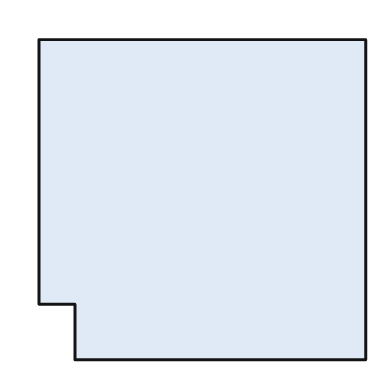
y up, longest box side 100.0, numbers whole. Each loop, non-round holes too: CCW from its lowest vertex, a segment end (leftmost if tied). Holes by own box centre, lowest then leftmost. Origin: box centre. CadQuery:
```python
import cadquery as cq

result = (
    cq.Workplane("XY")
    .moveTo(-39.0, -49.0)
    .lineTo(50.0, -49.0)
    .lineTo(50.0, 49.0)
    .lineTo(-50.0, 49.0)
    .lineTo(-50.0, -32.0)
    .lineTo(-39.0, -32.0)
    .close()
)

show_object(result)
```